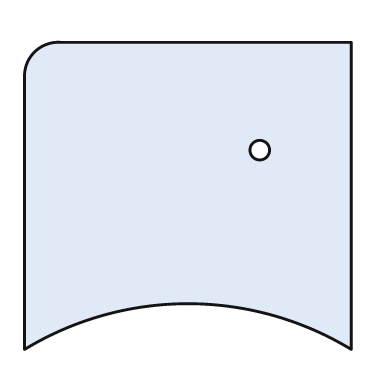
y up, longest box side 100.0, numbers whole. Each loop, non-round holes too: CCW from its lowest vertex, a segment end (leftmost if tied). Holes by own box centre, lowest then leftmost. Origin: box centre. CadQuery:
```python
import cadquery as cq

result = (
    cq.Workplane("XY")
    .moveTo(-50.0, -47.0)
    .threePointArc((0.0, -33.0), (50.0, -47.0))
    .lineTo(50.0, 47.0)
    .lineTo(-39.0, 47.0)
    .threePointArc((-47.0, 44.0), (-50.0, 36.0))
    .close()
    .moveTo(22.0, 14.0)
    .circle(3.0)
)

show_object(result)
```